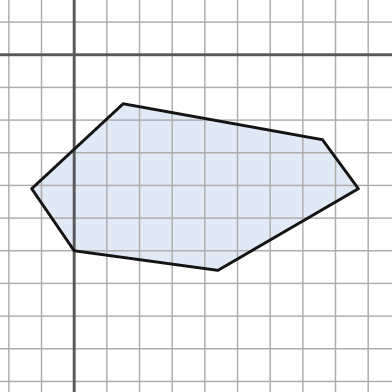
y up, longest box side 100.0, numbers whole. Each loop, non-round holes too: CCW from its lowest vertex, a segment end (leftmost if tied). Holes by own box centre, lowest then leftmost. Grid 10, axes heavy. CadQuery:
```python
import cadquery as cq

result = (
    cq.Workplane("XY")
    .moveTo(44.0, -66.0)
    .lineTo(87.0, -41.0)
    .lineTo(76.0, -26.0)
    .lineTo(15.0, -15.0)
    .lineTo(-13.0, -41.0)
    .lineTo(0.0, -60.0)
    .close()
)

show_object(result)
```